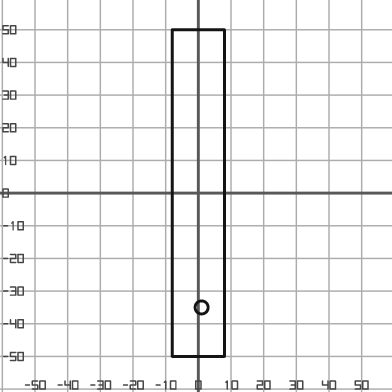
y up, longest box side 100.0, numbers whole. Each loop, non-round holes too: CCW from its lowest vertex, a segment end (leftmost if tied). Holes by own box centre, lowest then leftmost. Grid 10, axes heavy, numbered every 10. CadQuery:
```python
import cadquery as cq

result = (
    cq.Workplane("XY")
    .moveTo(-8.0, -50.0)
    .lineTo(8.0, -50.0)
    .lineTo(8.0, 50.0)
    .lineTo(-8.0, 50.0)
    .close()
    .moveTo(1.0, -35.0)
    .circle(2.0)
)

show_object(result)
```